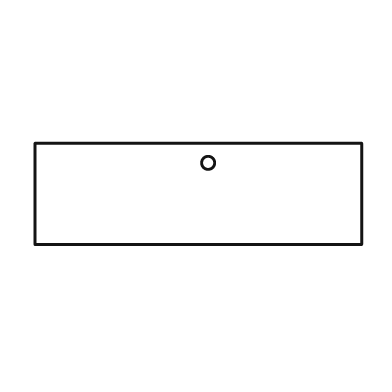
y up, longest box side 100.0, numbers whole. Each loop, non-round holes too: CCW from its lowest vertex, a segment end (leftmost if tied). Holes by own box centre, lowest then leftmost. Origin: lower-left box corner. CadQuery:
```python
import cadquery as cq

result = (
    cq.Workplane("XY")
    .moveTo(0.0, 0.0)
    .lineTo(100.0, 0.0)
    .lineTo(100.0, 31.0)
    .lineTo(0.0, 31.0)
    .close()
    .moveTo(53.0, 25.0)
    .circle(2.0)
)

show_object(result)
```